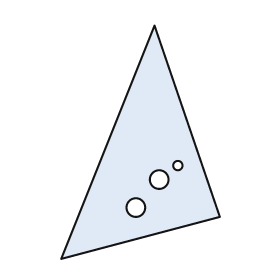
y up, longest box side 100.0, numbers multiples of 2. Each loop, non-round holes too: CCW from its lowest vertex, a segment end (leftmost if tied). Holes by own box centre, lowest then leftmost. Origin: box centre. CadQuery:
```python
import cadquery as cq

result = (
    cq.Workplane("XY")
    .moveTo(-34.0, -50.0)
    .lineTo(34.0, -32.0)
    .lineTo(6.0, 50.0)
    .close()
    .moveTo(-2.0, -28.0)
    .circle(4.0)
    .moveTo(8.0, -16.0)
    .circle(4.0)
    .moveTo(16.0, -10.0)
    .circle(2.0)
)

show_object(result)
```